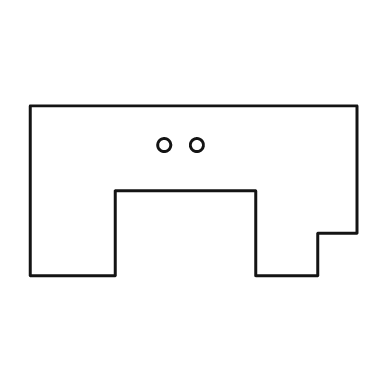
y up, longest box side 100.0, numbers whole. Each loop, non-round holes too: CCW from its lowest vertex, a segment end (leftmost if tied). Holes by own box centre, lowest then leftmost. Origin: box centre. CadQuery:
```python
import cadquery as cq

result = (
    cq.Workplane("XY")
    .moveTo(-50.0, -26.0)
    .lineTo(-24.0, -26.0)
    .lineTo(-24.0, 0.0)
    .lineTo(19.0, 0.0)
    .lineTo(19.0, -26.0)
    .lineTo(38.0, -26.0)
    .lineTo(38.0, -13.0)
    .lineTo(50.0, -13.0)
    .lineTo(50.0, 26.0)
    .lineTo(-50.0, 26.0)
    .close()
    .moveTo(-9.0, 14.0)
    .circle(2.0)
    .moveTo(1.0, 14.0)
    .circle(2.0)
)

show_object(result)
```